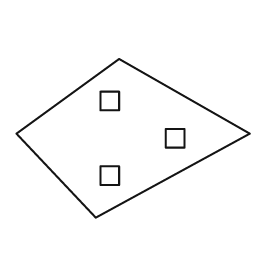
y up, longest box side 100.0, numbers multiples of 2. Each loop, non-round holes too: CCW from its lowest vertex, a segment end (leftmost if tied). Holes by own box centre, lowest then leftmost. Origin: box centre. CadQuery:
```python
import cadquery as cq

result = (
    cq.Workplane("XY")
    .moveTo(-16.0, -34.0)
    .lineTo(50.0, 2.0)
    .lineTo(-6.0, 34.0)
    .lineTo(-50.0, 2.0)
    .close()
    .moveTo(-14.0, -20.0)
    .lineTo(-6.0, -20.0)
    .lineTo(-6.0, -12.0)
    .lineTo(-14.0, -12.0)
    .close()
    .moveTo(14.0, -4.0)
    .lineTo(22.0, -4.0)
    .lineTo(22.0, 4.0)
    .lineTo(14.0, 4.0)
    .close()
    .moveTo(-14.0, 12.0)
    .lineTo(-6.0, 12.0)
    .lineTo(-6.0, 20.0)
    .lineTo(-14.0, 20.0)
    .close()
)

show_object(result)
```